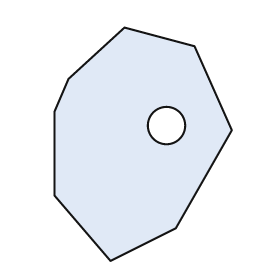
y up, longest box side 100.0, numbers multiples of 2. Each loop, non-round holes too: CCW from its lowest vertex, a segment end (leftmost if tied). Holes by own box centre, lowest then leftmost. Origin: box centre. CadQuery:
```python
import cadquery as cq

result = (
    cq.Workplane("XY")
    .moveTo(-14.0, -50.0)
    .lineTo(14.0, -36.0)
    .lineTo(38.0, 6.0)
    .lineTo(22.0, 42.0)
    .lineTo(-8.0, 50.0)
    .lineTo(-32.0, 28.0)
    .lineTo(-38.0, 14.0)
    .lineTo(-38.0, -22.0)
    .close()
    .moveTo(10.0, 8.0)
    .circle(8.0)
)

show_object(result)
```